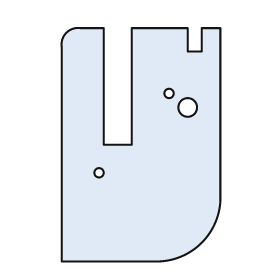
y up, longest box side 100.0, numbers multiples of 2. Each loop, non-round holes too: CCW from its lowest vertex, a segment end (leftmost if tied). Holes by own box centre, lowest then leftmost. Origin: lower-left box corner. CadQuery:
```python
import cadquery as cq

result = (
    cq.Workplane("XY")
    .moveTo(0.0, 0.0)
    .lineTo(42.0, 0.0)
    .threePointArc((60.0, 8.0), (68.0, 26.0))
    .lineTo(68.0, 100.0)
    .lineTo(60.0, 100.0)
    .lineTo(60.0, 90.0)
    .lineTo(54.0, 90.0)
    .lineTo(54.0, 100.0)
    .lineTo(30.0, 100.0)
    .lineTo(30.0, 50.0)
    .lineTo(18.0, 50.0)
    .lineTo(18.0, 100.0)
    .lineTo(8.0, 100.0)
    .threePointArc((2.0, 98.0), (0.0, 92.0))
    .close()
    .moveTo(16.0, 38.0)
    .circle(2.0)
    .moveTo(54.0, 66.0)
    .circle(4.0)
    .moveTo(46.0, 72.0)
    .circle(2.0)
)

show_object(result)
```